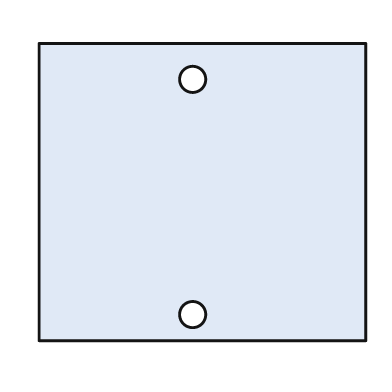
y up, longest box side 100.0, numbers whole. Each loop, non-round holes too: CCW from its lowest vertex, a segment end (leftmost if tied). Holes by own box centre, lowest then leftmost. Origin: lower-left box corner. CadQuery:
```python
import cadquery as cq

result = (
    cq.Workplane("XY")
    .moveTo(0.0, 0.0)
    .lineTo(100.0, 0.0)
    .lineTo(100.0, 91.0)
    .lineTo(0.0, 91.0)
    .close()
    .moveTo(47.0, 8.0)
    .circle(4.0)
    .moveTo(47.0, 80.0)
    .circle(4.0)
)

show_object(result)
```